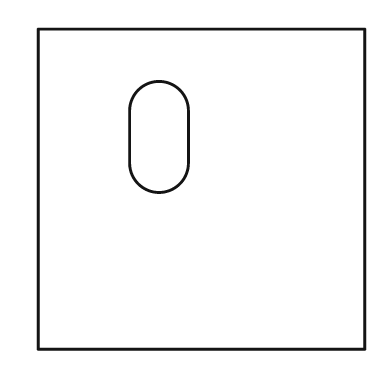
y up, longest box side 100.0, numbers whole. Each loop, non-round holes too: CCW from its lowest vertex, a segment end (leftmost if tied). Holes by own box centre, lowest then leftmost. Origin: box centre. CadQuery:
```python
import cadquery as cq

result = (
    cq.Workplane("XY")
    .moveTo(-50.0, -49.0)
    .lineTo(50.0, -49.0)
    .lineTo(50.0, 49.0)
    .lineTo(-50.0, 49.0)
    .close()
    .moveTo(-22.0, 8.0)
    .threePointArc((-13.0, -1.0), (-4.0, 8.0))
    .lineTo(-4.0, 24.0)
    .threePointArc((-13.0, 33.0), (-22.0, 24.0))
    .close()
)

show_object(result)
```